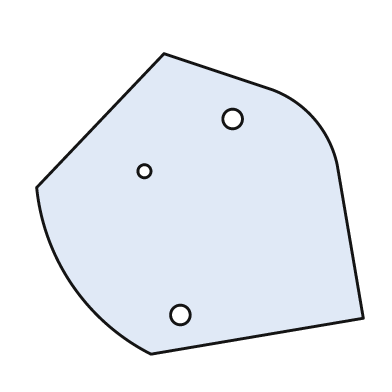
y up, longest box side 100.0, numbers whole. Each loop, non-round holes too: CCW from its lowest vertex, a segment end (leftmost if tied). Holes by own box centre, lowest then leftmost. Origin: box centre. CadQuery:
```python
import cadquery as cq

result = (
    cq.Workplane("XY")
    .moveTo(-15.0, -46.0)
    .lineTo(50.0, -35.0)
    .lineTo(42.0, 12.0)
    .threePointArc((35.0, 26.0), (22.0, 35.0))
    .lineTo(-11.0, 46.0)
    .lineTo(-50.0, 5.0)
    .threePointArc((-39.0, -25.0), (-15.0, -46.0))
    .close()
    .moveTo(-6.0, -34.0)
    .circle(3.0)
    .moveTo(-17.0, 10.0)
    .circle(2.0)
    .moveTo(10.0, 26.0)
    .circle(3.0)
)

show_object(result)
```